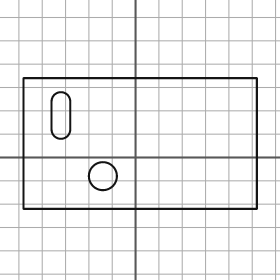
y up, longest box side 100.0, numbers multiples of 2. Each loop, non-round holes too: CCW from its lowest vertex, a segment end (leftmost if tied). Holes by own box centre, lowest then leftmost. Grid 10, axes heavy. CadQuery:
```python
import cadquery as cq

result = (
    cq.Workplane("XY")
    .moveTo(-48.0, -22.0)
    .lineTo(52.0, -22.0)
    .lineTo(52.0, 34.0)
    .lineTo(-48.0, 34.0)
    .close()
    .moveTo(-14.0, -8.0)
    .circle(6.0)
    .moveTo(-36.0, 12.0)
    .threePointArc((-32.0, 8.0), (-28.0, 12.0))
    .lineTo(-28.0, 24.0)
    .threePointArc((-32.0, 28.0), (-36.0, 24.0))
    .close()
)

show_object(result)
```